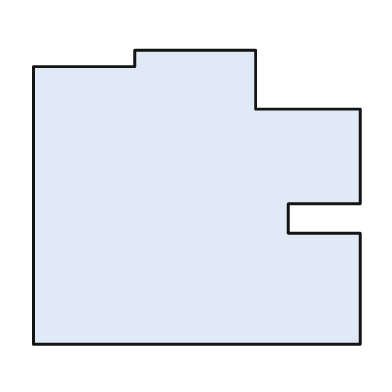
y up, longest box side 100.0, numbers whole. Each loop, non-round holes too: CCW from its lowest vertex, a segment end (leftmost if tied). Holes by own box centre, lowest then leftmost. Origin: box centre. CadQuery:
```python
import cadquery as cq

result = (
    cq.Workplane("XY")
    .moveTo(-50.0, -45.0)
    .lineTo(50.0, -45.0)
    .lineTo(50.0, -11.0)
    .lineTo(28.0, -11.0)
    .lineTo(28.0, -2.0)
    .lineTo(50.0, -2.0)
    .lineTo(50.0, 27.0)
    .lineTo(18.0, 27.0)
    .lineTo(18.0, 45.0)
    .lineTo(-19.0, 45.0)
    .lineTo(-19.0, 40.0)
    .lineTo(-50.0, 40.0)
    .close()
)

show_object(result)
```